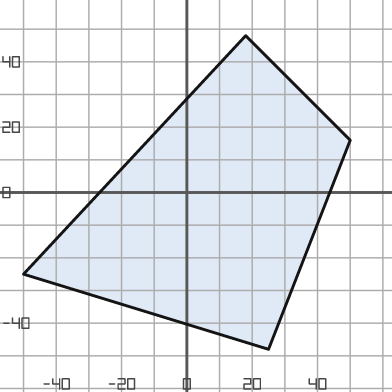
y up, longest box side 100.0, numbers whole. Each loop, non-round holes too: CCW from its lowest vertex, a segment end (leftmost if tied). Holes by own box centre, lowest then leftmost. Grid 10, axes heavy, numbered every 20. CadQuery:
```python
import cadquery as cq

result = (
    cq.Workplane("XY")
    .moveTo(25.0, -48.0)
    .lineTo(50.0, 16.0)
    .lineTo(18.0, 48.0)
    .lineTo(-50.0, -25.0)
    .close()
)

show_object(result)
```